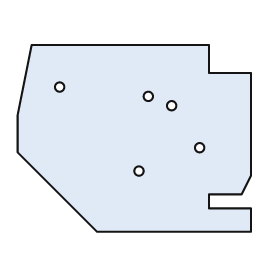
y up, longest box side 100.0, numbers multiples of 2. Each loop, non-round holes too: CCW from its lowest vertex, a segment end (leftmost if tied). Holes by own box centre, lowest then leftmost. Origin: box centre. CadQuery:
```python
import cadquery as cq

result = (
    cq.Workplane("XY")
    .moveTo(-16.0, -40.0)
    .lineTo(50.0, -40.0)
    .lineTo(50.0, -30.0)
    .lineTo(32.0, -30.0)
    .lineTo(32.0, -24.0)
    .lineTo(46.0, -24.0)
    .lineTo(50.0, -16.0)
    .lineTo(50.0, 28.0)
    .lineTo(32.0, 28.0)
    .lineTo(32.0, 40.0)
    .lineTo(-44.0, 40.0)
    .lineTo(-50.0, 10.0)
    .lineTo(-50.0, -6.0)
    .close()
    .moveTo(2.0, -14.0)
    .circle(2.0)
    .moveTo(28.0, -4.0)
    .circle(2.0)
    .moveTo(16.0, 14.0)
    .circle(2.0)
    .moveTo(6.0, 18.0)
    .circle(2.0)
    .moveTo(-32.0, 22.0)
    .circle(2.0)
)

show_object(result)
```